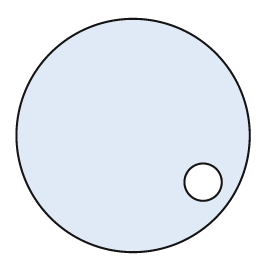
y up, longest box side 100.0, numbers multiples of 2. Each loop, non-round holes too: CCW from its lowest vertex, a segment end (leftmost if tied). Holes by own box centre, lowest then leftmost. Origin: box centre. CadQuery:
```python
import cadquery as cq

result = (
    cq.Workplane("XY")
    .moveTo(0.0, 0.0)
    .circle(50.0)
    .moveTo(30.0, -20.0)
    .circle(8.0)
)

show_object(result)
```